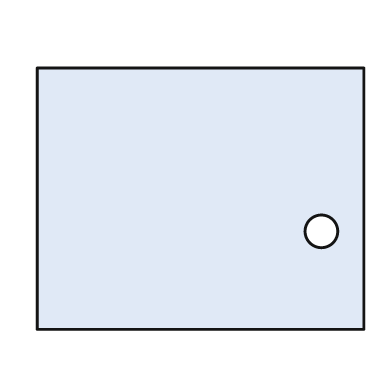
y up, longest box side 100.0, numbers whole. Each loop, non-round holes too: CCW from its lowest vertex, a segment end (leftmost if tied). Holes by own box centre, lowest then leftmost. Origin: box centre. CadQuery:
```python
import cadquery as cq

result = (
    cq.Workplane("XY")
    .moveTo(-50.0, -40.0)
    .lineTo(50.0, -40.0)
    .lineTo(50.0, 40.0)
    .lineTo(-50.0, 40.0)
    .close()
    .moveTo(37.0, -10.0)
    .circle(5.0)
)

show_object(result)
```